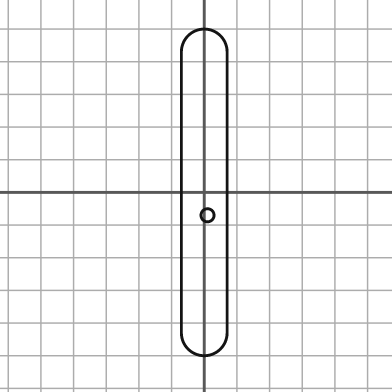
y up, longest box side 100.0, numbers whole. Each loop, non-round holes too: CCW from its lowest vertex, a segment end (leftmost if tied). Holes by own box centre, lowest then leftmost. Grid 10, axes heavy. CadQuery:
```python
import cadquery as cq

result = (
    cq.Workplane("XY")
    .moveTo(-7.0, -43.0)
    .threePointArc((0.0, -50.0), (7.0, -43.0))
    .lineTo(7.0, 43.0)
    .threePointArc((0.0, 50.0), (-7.0, 43.0))
    .close()
    .moveTo(1.0, -7.0)
    .circle(2.0)
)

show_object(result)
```